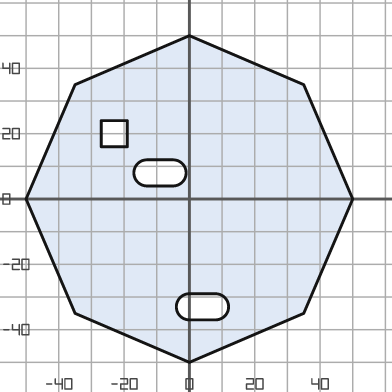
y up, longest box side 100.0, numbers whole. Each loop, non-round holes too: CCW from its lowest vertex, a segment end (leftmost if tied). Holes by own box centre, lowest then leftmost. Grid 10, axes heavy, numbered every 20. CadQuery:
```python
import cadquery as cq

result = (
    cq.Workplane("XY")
    .moveTo(0.0, -50.0)
    .lineTo(35.0, -35.0)
    .lineTo(50.0, 0.0)
    .lineTo(35.0, 35.0)
    .lineTo(0.0, 50.0)
    .lineTo(-35.0, 35.0)
    .lineTo(-50.0, 0.0)
    .lineTo(-35.0, -35.0)
    .close()
    .moveTo(0.0, -37.0)
    .lineTo(8.0, -37.0)
    .threePointArc((12.0, -33.0), (8.0, -29.0))
    .lineTo(0.0, -29.0)
    .threePointArc((-4.0, -33.0), (0.0, -37.0))
    .close()
    .moveTo(-13.0, 4.0)
    .lineTo(-5.0, 4.0)
    .threePointArc((-1.0, 8.0), (-5.0, 12.0))
    .lineTo(-13.0, 12.0)
    .threePointArc((-17.0, 8.0), (-13.0, 4.0))
    .close()
    .moveTo(-27.0, 16.0)
    .lineTo(-19.0, 16.0)
    .lineTo(-19.0, 24.0)
    .lineTo(-27.0, 24.0)
    .close()
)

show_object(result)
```